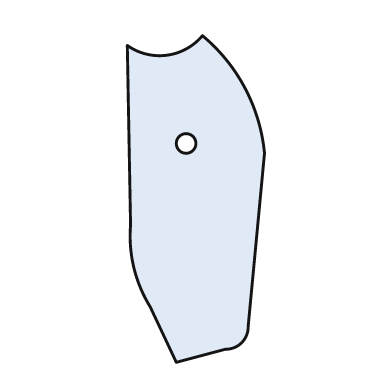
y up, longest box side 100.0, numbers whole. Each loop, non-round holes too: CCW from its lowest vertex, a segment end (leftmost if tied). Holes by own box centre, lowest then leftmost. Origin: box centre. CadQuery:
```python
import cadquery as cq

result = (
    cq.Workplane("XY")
    .moveTo(-6.0, -50.0)
    .lineTo(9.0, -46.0)
    .threePointArc((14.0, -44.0), (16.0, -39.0))
    .lineTo(21.0, 14.0)
    .threePointArc((15.0, 34.0), (2.0, 50.0))
    .threePointArc((-9.0, 44.0), (-21.0, 47.0))
    .lineTo(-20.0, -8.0)
    .threePointArc((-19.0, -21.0), (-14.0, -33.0))
    .close()
    .moveTo(-3.0, 17.0)
    .circle(3.0)
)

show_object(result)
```